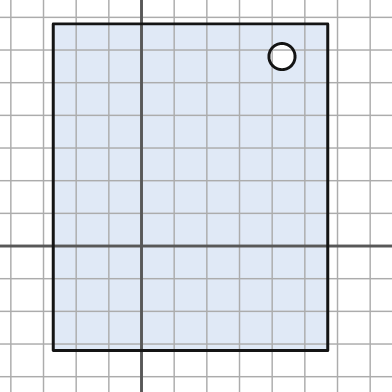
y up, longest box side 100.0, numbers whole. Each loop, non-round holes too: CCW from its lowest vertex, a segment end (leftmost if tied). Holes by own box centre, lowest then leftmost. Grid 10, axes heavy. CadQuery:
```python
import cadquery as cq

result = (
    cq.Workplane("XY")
    .moveTo(-27.0, -32.0)
    .lineTo(57.0, -32.0)
    .lineTo(57.0, 68.0)
    .lineTo(-27.0, 68.0)
    .close()
    .moveTo(43.0, 58.0)
    .circle(4.0)
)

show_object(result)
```